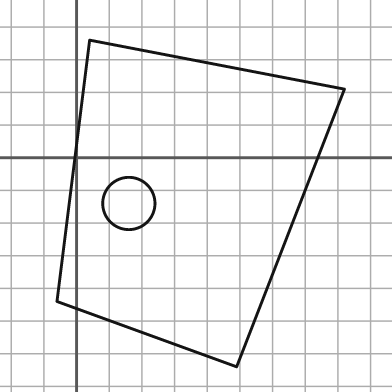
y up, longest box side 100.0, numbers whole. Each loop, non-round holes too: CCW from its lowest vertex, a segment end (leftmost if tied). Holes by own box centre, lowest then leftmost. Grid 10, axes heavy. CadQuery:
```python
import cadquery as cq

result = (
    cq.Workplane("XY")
    .moveTo(49.0, -64.0)
    .lineTo(82.0, 21.0)
    .lineTo(4.0, 36.0)
    .lineTo(-6.0, -44.0)
    .close()
    .moveTo(16.0, -14.0)
    .circle(8.0)
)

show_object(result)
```